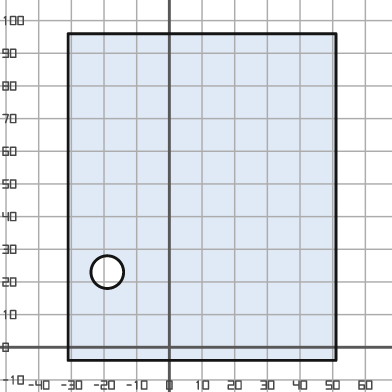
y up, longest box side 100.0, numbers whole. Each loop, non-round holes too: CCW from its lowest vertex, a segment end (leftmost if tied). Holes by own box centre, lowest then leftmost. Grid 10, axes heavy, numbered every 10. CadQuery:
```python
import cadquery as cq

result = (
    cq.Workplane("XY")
    .moveTo(-31.0, -4.0)
    .lineTo(51.0, -4.0)
    .lineTo(51.0, 96.0)
    .lineTo(-31.0, 96.0)
    .close()
    .moveTo(-19.0, 23.0)
    .circle(5.0)
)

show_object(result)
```